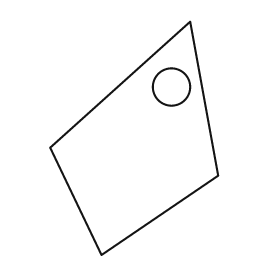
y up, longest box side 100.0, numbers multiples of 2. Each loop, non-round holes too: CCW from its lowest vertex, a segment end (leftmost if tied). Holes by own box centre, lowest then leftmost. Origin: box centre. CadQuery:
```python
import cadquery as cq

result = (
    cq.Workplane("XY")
    .moveTo(-14.0, -50.0)
    .lineTo(36.0, -16.0)
    .lineTo(24.0, 50.0)
    .lineTo(-36.0, -4.0)
    .close()
    .moveTo(16.0, 22.0)
    .circle(8.0)
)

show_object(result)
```